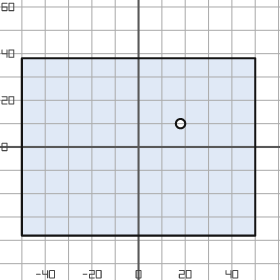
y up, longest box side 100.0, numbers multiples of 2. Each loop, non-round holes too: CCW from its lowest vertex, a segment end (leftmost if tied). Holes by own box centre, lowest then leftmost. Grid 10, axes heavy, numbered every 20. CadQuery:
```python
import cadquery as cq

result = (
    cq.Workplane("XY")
    .moveTo(-50.0, -38.0)
    .lineTo(50.0, -38.0)
    .lineTo(50.0, 38.0)
    .lineTo(-50.0, 38.0)
    .close()
    .moveTo(18.0, 10.0)
    .circle(2.0)
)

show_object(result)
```